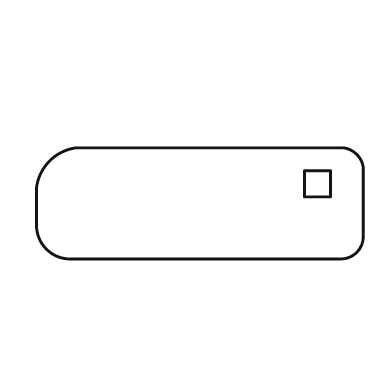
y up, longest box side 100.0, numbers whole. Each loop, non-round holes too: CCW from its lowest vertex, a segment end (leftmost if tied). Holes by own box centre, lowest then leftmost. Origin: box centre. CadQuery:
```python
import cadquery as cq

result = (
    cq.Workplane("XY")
    .moveTo(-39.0, -17.0)
    .lineTo(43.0, -17.0)
    .threePointArc((48.0, -15.0), (50.0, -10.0))
    .lineTo(50.0, 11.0)
    .threePointArc((48.0, 15.0), (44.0, 17.0))
    .lineTo(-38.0, 17.0)
    .threePointArc((-46.0, 13.0), (-50.0, 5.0))
    .lineTo(-50.0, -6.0)
    .threePointArc((-47.0, -14.0), (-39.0, -17.0))
    .close()
    .moveTo(32.0, 2.0)
    .lineTo(40.0, 2.0)
    .lineTo(40.0, 10.0)
    .lineTo(32.0, 10.0)
    .close()
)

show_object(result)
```